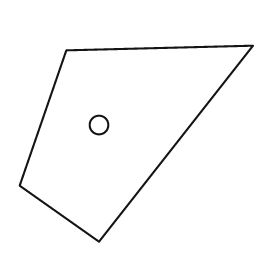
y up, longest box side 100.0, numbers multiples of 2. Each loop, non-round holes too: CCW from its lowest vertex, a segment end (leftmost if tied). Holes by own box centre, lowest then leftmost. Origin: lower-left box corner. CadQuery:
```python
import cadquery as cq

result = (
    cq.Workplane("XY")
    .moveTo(34.0, 0.0)
    .lineTo(100.0, 84.0)
    .lineTo(20.0, 82.0)
    .lineTo(0.0, 24.0)
    .close()
    .moveTo(34.0, 50.0)
    .circle(4.0)
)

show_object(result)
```